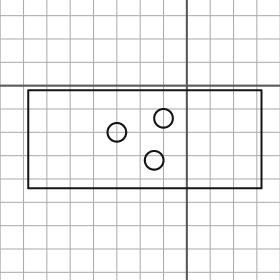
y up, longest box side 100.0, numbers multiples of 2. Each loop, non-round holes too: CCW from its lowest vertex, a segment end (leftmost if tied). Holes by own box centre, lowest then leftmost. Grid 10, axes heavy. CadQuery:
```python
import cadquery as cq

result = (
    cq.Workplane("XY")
    .moveTo(-68.0, -44.0)
    .lineTo(32.0, -44.0)
    .lineTo(32.0, -2.0)
    .lineTo(-68.0, -2.0)
    .close()
    .moveTo(-14.0, -32.0)
    .circle(4.0)
    .moveTo(-30.0, -20.0)
    .circle(4.0)
    .moveTo(-10.0, -14.0)
    .circle(4.0)
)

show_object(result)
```